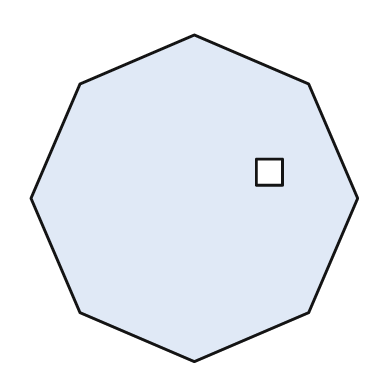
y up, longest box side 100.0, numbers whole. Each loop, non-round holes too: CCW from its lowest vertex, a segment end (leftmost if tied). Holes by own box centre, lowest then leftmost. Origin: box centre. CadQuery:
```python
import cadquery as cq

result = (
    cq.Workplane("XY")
    .moveTo(0.0, -50.0)
    .lineTo(35.0, -35.0)
    .lineTo(50.0, 0.0)
    .lineTo(35.0, 35.0)
    .lineTo(0.0, 50.0)
    .lineTo(-35.0, 35.0)
    .lineTo(-50.0, 0.0)
    .lineTo(-35.0, -35.0)
    .close()
    .moveTo(19.0, 4.0)
    .lineTo(27.0, 4.0)
    .lineTo(27.0, 12.0)
    .lineTo(19.0, 12.0)
    .close()
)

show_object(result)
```